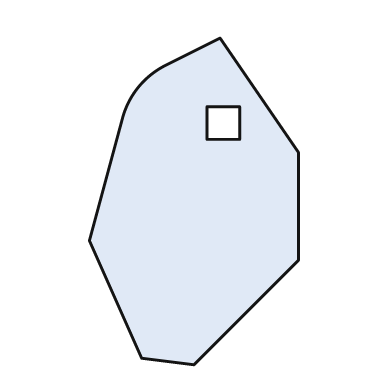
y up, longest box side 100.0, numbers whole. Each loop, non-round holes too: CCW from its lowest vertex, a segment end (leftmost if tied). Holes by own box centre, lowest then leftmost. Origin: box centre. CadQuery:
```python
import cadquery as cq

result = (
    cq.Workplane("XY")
    .moveTo(0.0, -50.0)
    .lineTo(32.0, -18.0)
    .lineTo(32.0, 15.0)
    .lineTo(8.0, 50.0)
    .lineTo(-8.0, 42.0)
    .threePointArc((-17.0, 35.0), (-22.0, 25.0))
    .lineTo(-32.0, -12.0)
    .lineTo(-16.0, -48.0)
    .close()
    .moveTo(4.0, 19.0)
    .lineTo(14.0, 19.0)
    .lineTo(14.0, 29.0)
    .lineTo(4.0, 29.0)
    .close()
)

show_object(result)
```